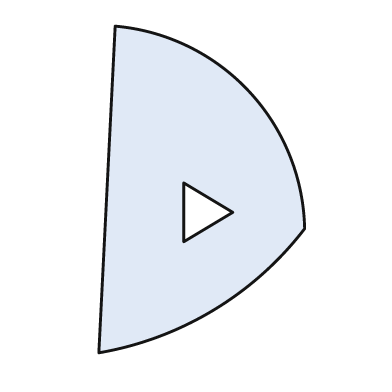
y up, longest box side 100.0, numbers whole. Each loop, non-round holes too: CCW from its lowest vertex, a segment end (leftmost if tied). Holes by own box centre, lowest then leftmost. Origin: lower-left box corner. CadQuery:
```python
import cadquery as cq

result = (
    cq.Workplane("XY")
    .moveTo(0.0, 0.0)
    .threePointArc((35.0, 13.0), (63.0, 38.0))
    .threePointArc((46.0, 80.0), (5.0, 100.0))
    .close()
    .moveTo(26.0, 34.0)
    .lineTo(41.0, 43.0)
    .lineTo(26.0, 52.0)
    .close()
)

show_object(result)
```